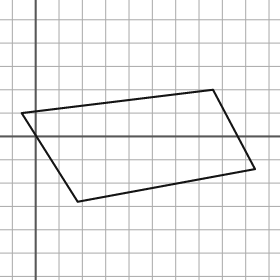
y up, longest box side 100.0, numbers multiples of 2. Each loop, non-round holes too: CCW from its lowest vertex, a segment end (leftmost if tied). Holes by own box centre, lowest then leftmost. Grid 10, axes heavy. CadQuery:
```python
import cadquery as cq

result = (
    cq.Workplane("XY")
    .moveTo(18.0, -28.0)
    .lineTo(94.0, -14.0)
    .lineTo(76.0, 20.0)
    .lineTo(-6.0, 10.0)
    .close()
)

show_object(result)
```